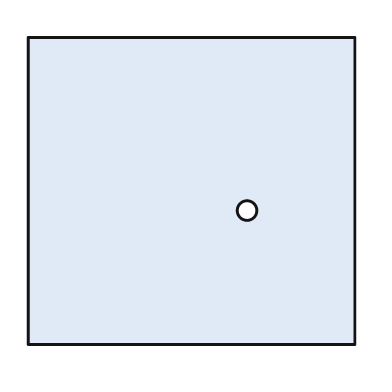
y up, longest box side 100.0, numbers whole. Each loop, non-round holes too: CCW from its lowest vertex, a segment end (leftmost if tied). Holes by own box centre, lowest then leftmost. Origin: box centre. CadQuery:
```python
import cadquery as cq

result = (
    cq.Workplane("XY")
    .moveTo(-50.0, -47.0)
    .lineTo(50.0, -47.0)
    .lineTo(50.0, 47.0)
    .lineTo(-50.0, 47.0)
    .close()
    .moveTo(17.0, -6.0)
    .circle(3.0)
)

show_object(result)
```